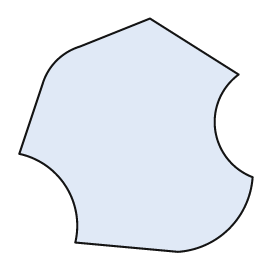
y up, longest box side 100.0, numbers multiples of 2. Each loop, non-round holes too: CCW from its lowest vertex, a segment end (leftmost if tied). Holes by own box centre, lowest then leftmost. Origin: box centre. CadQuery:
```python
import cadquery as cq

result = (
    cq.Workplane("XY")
    .moveTo(18.0, -50.0)
    .threePointArc((40.0, -40.0), (50.0, -18.0))
    .threePointArc((34.0, 2.0), (44.0, 26.0))
    .lineTo(6.0, 50.0)
    .lineTo(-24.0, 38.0)
    .threePointArc((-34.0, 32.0), (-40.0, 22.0))
    .lineTo(-50.0, -8.0)
    .threePointArc((-30.0, -22.0), (-26.0, -46.0))
    .close()
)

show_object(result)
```